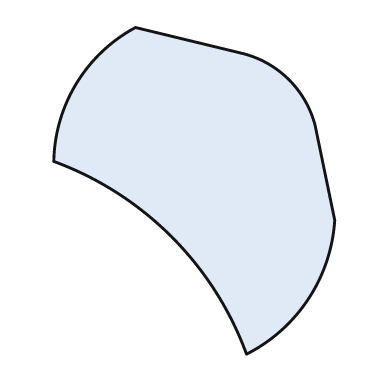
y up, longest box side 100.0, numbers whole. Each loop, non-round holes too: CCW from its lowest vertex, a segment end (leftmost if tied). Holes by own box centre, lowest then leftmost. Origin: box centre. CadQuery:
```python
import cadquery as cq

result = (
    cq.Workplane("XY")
    .moveTo(16.0, -50.0)
    .threePointArc((35.0, -33.0), (43.0, -9.0))
    .lineTo(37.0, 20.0)
    .threePointArc((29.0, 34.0), (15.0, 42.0))
    .lineTo(-18.0, 50.0)
    .threePointArc((-36.0, 33.0), (-43.0, 9.0))
    .threePointArc((-7.0, -14.0), (16.0, -50.0))
    .close()
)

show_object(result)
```